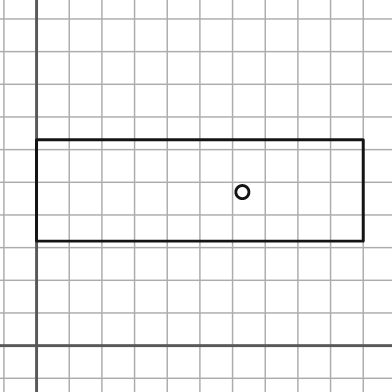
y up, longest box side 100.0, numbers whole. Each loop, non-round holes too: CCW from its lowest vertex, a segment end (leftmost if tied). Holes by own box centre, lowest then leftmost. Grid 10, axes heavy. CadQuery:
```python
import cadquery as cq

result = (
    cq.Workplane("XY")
    .moveTo(0.0, 32.0)
    .lineTo(100.0, 32.0)
    .lineTo(100.0, 63.0)
    .lineTo(0.0, 63.0)
    .close()
    .moveTo(63.0, 47.0)
    .circle(2.0)
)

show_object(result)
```